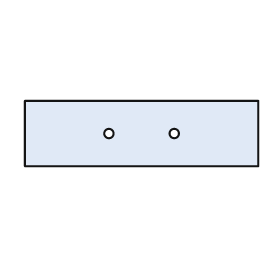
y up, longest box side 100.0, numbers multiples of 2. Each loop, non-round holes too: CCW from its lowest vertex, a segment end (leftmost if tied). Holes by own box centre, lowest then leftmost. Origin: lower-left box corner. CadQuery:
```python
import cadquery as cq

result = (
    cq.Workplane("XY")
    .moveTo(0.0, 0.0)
    .lineTo(100.0, 0.0)
    .lineTo(100.0, 28.0)
    .lineTo(0.0, 28.0)
    .close()
    .moveTo(36.0, 14.0)
    .circle(2.0)
    .moveTo(64.0, 14.0)
    .circle(2.0)
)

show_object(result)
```